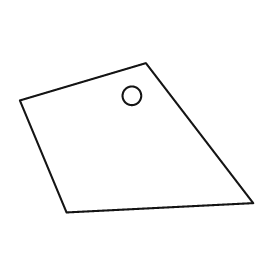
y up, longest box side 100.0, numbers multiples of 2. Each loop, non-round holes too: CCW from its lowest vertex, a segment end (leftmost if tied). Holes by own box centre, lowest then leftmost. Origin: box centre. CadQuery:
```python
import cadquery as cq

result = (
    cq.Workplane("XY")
    .moveTo(-30.0, -32.0)
    .lineTo(50.0, -28.0)
    .lineTo(4.0, 32.0)
    .lineTo(-50.0, 16.0)
    .close()
    .moveTo(-2.0, 18.0)
    .circle(4.0)
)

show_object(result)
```